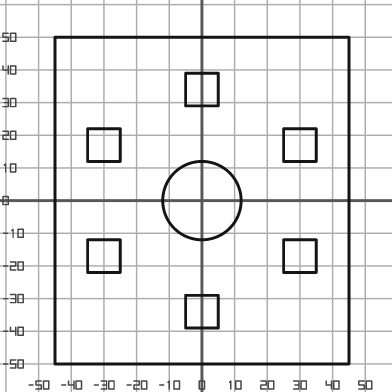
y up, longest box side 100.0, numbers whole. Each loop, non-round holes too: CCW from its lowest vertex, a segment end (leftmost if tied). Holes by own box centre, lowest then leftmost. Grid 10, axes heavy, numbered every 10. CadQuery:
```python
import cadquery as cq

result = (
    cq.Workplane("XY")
    .moveTo(-45.0, -50.0)
    .lineTo(45.0, -50.0)
    .lineTo(45.0, 50.0)
    .lineTo(-45.0, 50.0)
    .close()
    .moveTo(-5.0, -39.0)
    .lineTo(5.0, -39.0)
    .lineTo(5.0, -29.0)
    .lineTo(-5.0, -29.0)
    .close()
    .moveTo(-35.0, -22.0)
    .lineTo(-25.0, -22.0)
    .lineTo(-25.0, -12.0)
    .lineTo(-35.0, -12.0)
    .close()
    .moveTo(25.0, -22.0)
    .lineTo(35.0, -22.0)
    .lineTo(35.0, -12.0)
    .lineTo(25.0, -12.0)
    .close()
    .moveTo(0.0, 0.0)
    .circle(12.0)
    .moveTo(-35.0, 12.0)
    .lineTo(-25.0, 12.0)
    .lineTo(-25.0, 22.0)
    .lineTo(-35.0, 22.0)
    .close()
    .moveTo(25.0, 12.0)
    .lineTo(35.0, 12.0)
    .lineTo(35.0, 22.0)
    .lineTo(25.0, 22.0)
    .close()
    .moveTo(-5.0, 29.0)
    .lineTo(5.0, 29.0)
    .lineTo(5.0, 39.0)
    .lineTo(-5.0, 39.0)
    .close()
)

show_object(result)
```